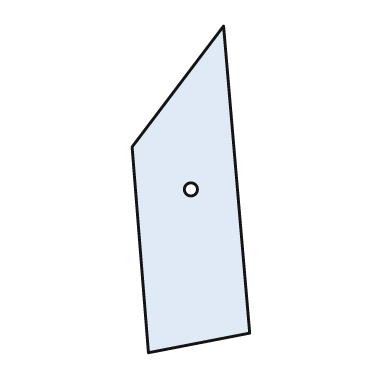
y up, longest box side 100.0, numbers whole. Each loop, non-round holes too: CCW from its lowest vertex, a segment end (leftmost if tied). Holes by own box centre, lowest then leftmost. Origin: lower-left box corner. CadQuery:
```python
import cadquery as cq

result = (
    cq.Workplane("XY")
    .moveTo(5.0, 0.0)
    .lineTo(36.0, 6.0)
    .lineTo(28.0, 100.0)
    .lineTo(0.0, 63.0)
    .close()
    .moveTo(18.0, 50.0)
    .circle(2.0)
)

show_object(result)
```